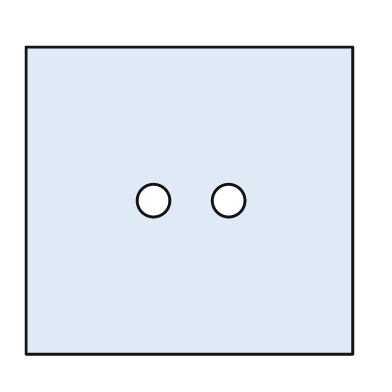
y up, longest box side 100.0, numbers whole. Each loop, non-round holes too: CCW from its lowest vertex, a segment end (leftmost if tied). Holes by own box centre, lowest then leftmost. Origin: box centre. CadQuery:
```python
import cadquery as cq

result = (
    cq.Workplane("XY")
    .moveTo(-50.0, -47.0)
    .lineTo(50.0, -47.0)
    .lineTo(50.0, 47.0)
    .lineTo(-50.0, 47.0)
    .close()
    .moveTo(-11.0, 0.0)
    .circle(5.0)
    .moveTo(12.0, 0.0)
    .circle(5.0)
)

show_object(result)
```